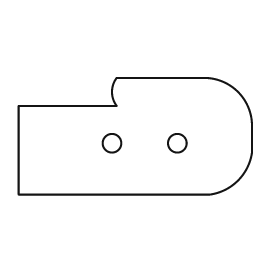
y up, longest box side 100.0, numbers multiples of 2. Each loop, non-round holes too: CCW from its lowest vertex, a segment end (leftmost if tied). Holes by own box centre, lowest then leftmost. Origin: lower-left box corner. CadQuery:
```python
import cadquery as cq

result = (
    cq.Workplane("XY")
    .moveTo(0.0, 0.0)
    .lineTo(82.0, 0.0)
    .threePointArc((94.0, 6.0), (100.0, 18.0))
    .lineTo(100.0, 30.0)
    .threePointArc((94.0, 44.0), (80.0, 50.0))
    .lineTo(42.0, 50.0)
    .threePointArc((40.0, 44.0), (42.0, 38.0))
    .lineTo(0.0, 38.0)
    .close()
    .moveTo(40.0, 22.0)
    .circle(4.0)
    .moveTo(68.0, 22.0)
    .circle(4.0)
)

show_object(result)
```